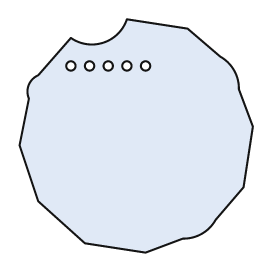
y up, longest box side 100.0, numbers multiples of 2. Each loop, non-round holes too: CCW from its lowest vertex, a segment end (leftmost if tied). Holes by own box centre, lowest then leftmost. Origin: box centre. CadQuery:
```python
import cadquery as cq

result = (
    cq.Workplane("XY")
    .moveTo(4.0, -50.0)
    .lineTo(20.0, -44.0)
    .threePointArc((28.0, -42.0), (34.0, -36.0))
    .lineTo(46.0, -22.0)
    .lineTo(50.0, 4.0)
    .lineTo(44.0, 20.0)
    .threePointArc((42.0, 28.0), (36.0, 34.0))
    .lineTo(22.0, 46.0)
    .lineTo(-4.0, 50.0)
    .threePointArc((-14.0, 40.0), (-28.0, 42.0))
    .lineTo(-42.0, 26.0)
    .threePointArc((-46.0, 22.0), (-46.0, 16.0))
    .lineTo(-50.0, -4.0)
    .lineTo(-42.0, -28.0)
    .lineTo(-22.0, -46.0)
    .close()
    .moveTo(-28.0, 30.0)
    .circle(2.0)
    .moveTo(-20.0, 30.0)
    .circle(2.0)
    .moveTo(-12.0, 30.0)
    .circle(2.0)
    .moveTo(-4.0, 30.0)
    .circle(2.0)
    .moveTo(4.0, 30.0)
    .circle(2.0)
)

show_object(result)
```